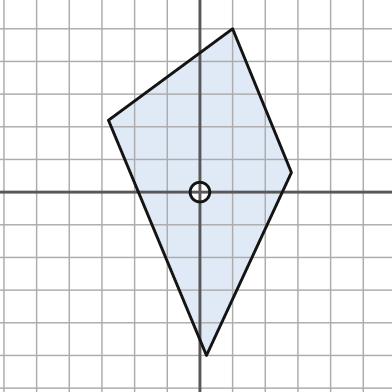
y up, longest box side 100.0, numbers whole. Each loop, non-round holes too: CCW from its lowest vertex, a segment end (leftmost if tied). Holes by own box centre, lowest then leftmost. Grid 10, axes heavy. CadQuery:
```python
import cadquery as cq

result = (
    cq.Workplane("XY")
    .moveTo(2.0, -50.0)
    .lineTo(28.0, 6.0)
    .lineTo(10.0, 50.0)
    .lineTo(-28.0, 22.0)
    .close()
    .moveTo(0.0, 0.0)
    .circle(3.0)
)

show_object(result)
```